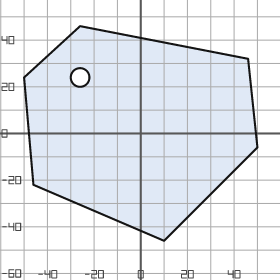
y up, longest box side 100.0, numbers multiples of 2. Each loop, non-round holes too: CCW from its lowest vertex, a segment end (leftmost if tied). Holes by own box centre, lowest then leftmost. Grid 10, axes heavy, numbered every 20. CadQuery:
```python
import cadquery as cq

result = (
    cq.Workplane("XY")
    .moveTo(10.0, -46.0)
    .lineTo(50.0, -6.0)
    .lineTo(46.0, 32.0)
    .lineTo(-26.0, 46.0)
    .lineTo(-50.0, 24.0)
    .lineTo(-46.0, -22.0)
    .close()
    .moveTo(-26.0, 24.0)
    .circle(4.0)
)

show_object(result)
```